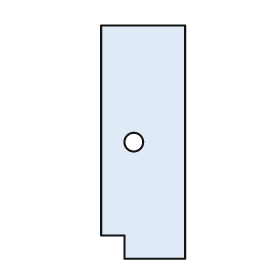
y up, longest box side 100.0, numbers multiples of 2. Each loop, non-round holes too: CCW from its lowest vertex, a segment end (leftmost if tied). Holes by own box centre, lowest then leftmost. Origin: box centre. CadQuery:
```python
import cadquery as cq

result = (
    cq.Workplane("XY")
    .moveTo(-8.0, -50.0)
    .lineTo(18.0, -50.0)
    .lineTo(18.0, 50.0)
    .lineTo(-18.0, 50.0)
    .lineTo(-18.0, -40.0)
    .lineTo(-8.0, -40.0)
    .close()
    .moveTo(-4.0, 0.0)
    .circle(4.0)
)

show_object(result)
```